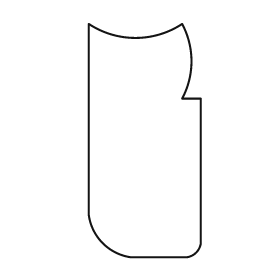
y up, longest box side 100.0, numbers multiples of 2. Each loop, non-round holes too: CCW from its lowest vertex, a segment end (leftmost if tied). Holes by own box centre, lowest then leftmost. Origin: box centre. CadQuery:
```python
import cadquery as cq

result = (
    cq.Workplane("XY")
    .moveTo(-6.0, -50.0)
    .lineTo(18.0, -50.0)
    .threePointArc((22.0, -48.0), (24.0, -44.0))
    .lineTo(24.0, 18.0)
    .lineTo(16.0, 18.0)
    .threePointArc((20.0, 34.0), (16.0, 50.0))
    .threePointArc((-4.0, 44.0), (-24.0, 50.0))
    .lineTo(-24.0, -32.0)
    .threePointArc((-18.0, -44.0), (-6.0, -50.0))
    .close()
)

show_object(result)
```